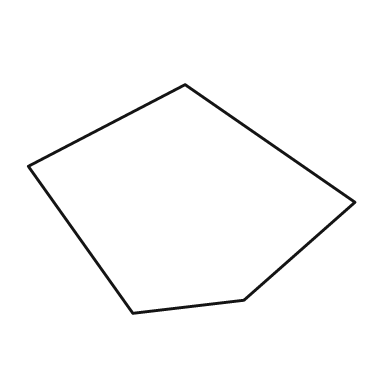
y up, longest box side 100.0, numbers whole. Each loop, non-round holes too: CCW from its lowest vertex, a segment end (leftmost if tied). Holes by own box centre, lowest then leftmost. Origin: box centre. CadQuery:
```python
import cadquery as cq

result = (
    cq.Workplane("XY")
    .moveTo(-18.0, -35.0)
    .lineTo(16.0, -31.0)
    .lineTo(50.0, -1.0)
    .lineTo(-2.0, 35.0)
    .lineTo(-50.0, 10.0)
    .close()
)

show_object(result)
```